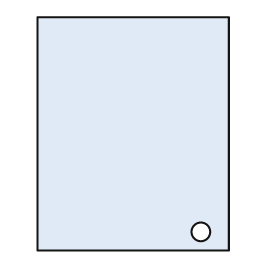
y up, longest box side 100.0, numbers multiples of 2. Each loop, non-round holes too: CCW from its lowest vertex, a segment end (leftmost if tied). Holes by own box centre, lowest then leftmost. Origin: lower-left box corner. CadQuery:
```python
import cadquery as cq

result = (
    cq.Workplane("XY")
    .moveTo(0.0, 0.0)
    .lineTo(82.0, 0.0)
    .lineTo(82.0, 100.0)
    .lineTo(0.0, 100.0)
    .close()
    .moveTo(70.0, 8.0)
    .circle(4.0)
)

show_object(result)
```